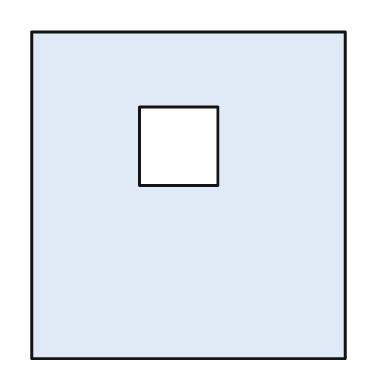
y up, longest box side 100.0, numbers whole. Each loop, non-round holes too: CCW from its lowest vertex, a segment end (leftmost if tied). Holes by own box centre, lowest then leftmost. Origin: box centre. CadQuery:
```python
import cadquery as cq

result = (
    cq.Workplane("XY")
    .moveTo(-48.0, -50.0)
    .lineTo(48.0, -50.0)
    .lineTo(48.0, 50.0)
    .lineTo(-48.0, 50.0)
    .close()
    .moveTo(-15.0, 3.0)
    .lineTo(9.0, 3.0)
    .lineTo(9.0, 27.0)
    .lineTo(-15.0, 27.0)
    .close()
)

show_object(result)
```